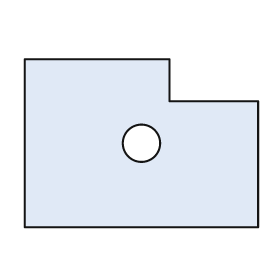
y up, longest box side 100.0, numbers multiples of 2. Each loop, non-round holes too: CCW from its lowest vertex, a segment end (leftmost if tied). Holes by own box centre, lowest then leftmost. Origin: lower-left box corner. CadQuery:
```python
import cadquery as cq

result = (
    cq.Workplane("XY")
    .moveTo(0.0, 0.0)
    .lineTo(100.0, 0.0)
    .lineTo(100.0, 54.0)
    .lineTo(62.0, 54.0)
    .lineTo(62.0, 72.0)
    .lineTo(0.0, 72.0)
    .close()
    .moveTo(50.0, 36.0)
    .circle(8.0)
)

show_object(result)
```